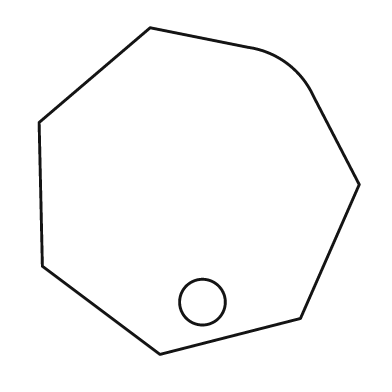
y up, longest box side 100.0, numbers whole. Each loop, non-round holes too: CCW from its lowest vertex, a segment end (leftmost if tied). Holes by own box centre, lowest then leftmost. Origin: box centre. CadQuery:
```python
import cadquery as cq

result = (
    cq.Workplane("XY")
    .moveTo(-12.0, -50.0)
    .lineTo(31.0, -39.0)
    .lineTo(49.0, 2.0)
    .lineTo(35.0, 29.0)
    .threePointArc((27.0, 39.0), (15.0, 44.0))
    .lineTo(-15.0, 50.0)
    .lineTo(-49.0, 21.0)
    .lineTo(-48.0, -23.0)
    .close()
    .moveTo(1.0, -34.0)
    .circle(7.0)
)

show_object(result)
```